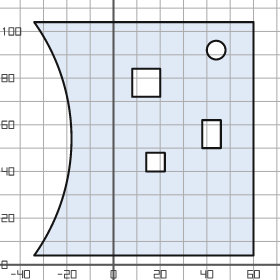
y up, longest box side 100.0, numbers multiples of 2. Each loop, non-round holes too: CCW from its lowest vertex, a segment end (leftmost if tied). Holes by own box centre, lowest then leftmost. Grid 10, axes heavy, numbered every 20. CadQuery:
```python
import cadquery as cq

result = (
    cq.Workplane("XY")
    .moveTo(-34.0, 4.0)
    .lineTo(60.0, 4.0)
    .lineTo(60.0, 104.0)
    .lineTo(-34.0, 104.0)
    .threePointArc((-18.0, 54.0), (-34.0, 4.0))
    .close()
    .moveTo(14.0, 40.0)
    .lineTo(22.0, 40.0)
    .lineTo(22.0, 48.0)
    .lineTo(14.0, 48.0)
    .close()
    .moveTo(38.0, 50.0)
    .lineTo(46.0, 50.0)
    .lineTo(46.0, 62.0)
    .lineTo(38.0, 62.0)
    .close()
    .moveTo(8.0, 72.0)
    .lineTo(20.0, 72.0)
    .lineTo(20.0, 84.0)
    .lineTo(8.0, 84.0)
    .close()
    .moveTo(44.0, 92.0)
    .circle(4.0)
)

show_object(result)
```